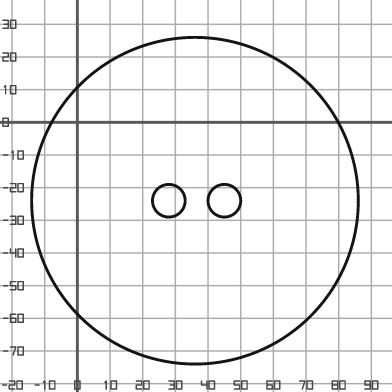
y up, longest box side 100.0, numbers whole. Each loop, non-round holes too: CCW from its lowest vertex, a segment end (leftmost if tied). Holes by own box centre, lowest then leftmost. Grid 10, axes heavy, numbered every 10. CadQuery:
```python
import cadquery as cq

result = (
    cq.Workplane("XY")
    .moveTo(36.0, -24.0)
    .circle(50.0)
    .moveTo(28.0, -24.0)
    .circle(5.0)
    .moveTo(45.0, -24.0)
    .circle(5.0)
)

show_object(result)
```